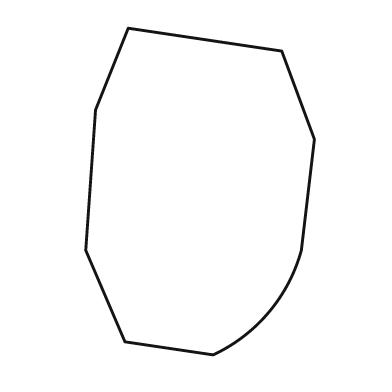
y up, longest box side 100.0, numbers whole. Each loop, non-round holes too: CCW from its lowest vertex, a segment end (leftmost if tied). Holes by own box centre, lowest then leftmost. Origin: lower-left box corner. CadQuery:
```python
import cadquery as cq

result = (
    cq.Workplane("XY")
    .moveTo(39.0, 0.0)
    .threePointArc((56.0, 13.0), (66.0, 32.0))
    .lineTo(70.0, 66.0)
    .lineTo(60.0, 93.0)
    .lineTo(13.0, 100.0)
    .lineTo(3.0, 75.0)
    .lineTo(0.0, 32.0)
    .lineTo(12.0, 4.0)
    .close()
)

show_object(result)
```